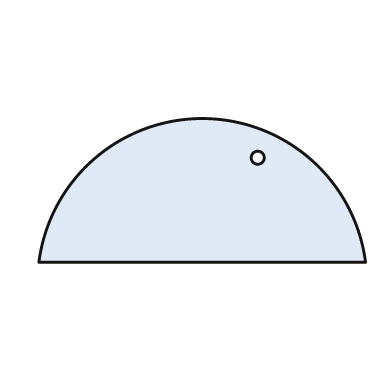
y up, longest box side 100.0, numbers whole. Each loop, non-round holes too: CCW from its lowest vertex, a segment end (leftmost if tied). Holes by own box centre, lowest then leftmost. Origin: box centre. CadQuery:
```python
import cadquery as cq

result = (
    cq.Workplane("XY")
    .moveTo(-50.0, -22.0)
    .lineTo(50.0, -22.0)
    .threePointArc((0.0, 22.0), (-50.0, -22.0))
    .close()
    .moveTo(17.0, 10.0)
    .circle(2.0)
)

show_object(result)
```